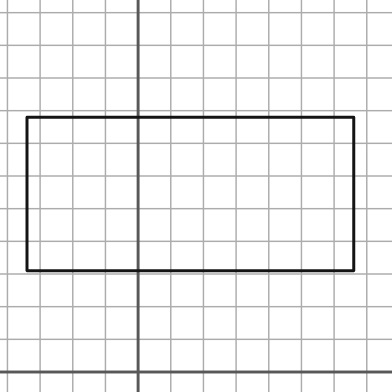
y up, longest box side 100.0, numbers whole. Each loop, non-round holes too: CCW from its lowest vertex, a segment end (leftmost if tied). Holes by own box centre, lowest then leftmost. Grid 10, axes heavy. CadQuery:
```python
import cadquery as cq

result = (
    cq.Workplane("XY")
    .moveTo(-34.0, 31.0)
    .lineTo(66.0, 31.0)
    .lineTo(66.0, 78.0)
    .lineTo(-34.0, 78.0)
    .close()
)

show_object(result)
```